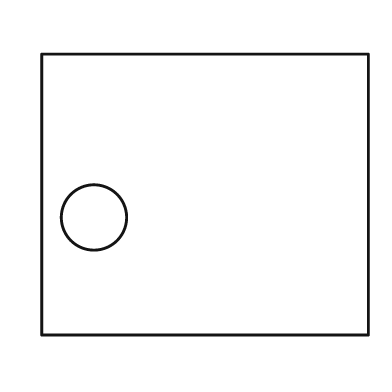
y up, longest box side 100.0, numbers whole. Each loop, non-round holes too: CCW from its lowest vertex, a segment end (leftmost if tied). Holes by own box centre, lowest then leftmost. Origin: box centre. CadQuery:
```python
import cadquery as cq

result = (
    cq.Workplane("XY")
    .moveTo(-50.0, -43.0)
    .lineTo(50.0, -43.0)
    .lineTo(50.0, 43.0)
    .lineTo(-50.0, 43.0)
    .close()
    .moveTo(-34.0, -7.0)
    .circle(10.0)
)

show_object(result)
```